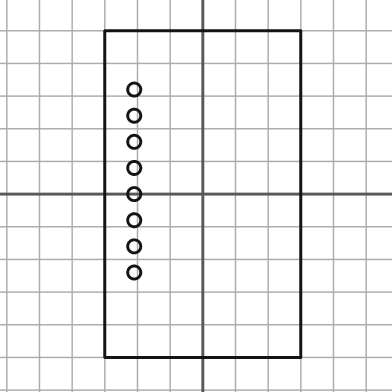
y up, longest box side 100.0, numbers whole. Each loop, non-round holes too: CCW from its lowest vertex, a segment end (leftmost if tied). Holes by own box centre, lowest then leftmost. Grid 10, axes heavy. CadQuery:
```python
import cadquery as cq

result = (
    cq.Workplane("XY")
    .moveTo(-30.0, -50.0)
    .lineTo(30.0, -50.0)
    .lineTo(30.0, 50.0)
    .lineTo(-30.0, 50.0)
    .close()
    .moveTo(-21.0, -24.0)
    .circle(2.0)
    .moveTo(-21.0, -16.0)
    .circle(2.0)
    .moveTo(-21.0, -8.0)
    .circle(2.0)
    .moveTo(-21.0, 0.0)
    .circle(2.0)
    .moveTo(-21.0, 8.0)
    .circle(2.0)
    .moveTo(-21.0, 16.0)
    .circle(2.0)
    .moveTo(-21.0, 24.0)
    .circle(2.0)
    .moveTo(-21.0, 32.0)
    .circle(2.0)
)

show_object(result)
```